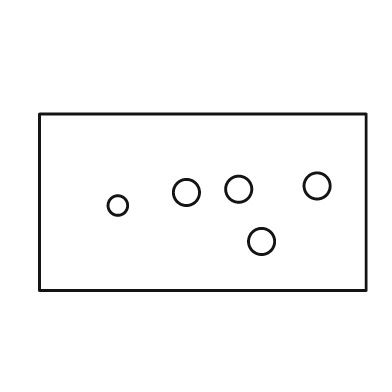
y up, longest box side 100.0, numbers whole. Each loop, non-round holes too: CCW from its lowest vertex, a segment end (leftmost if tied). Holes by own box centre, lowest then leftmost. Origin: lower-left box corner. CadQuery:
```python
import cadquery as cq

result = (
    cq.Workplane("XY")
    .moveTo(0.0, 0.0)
    .lineTo(100.0, 0.0)
    .lineTo(100.0, 54.0)
    .lineTo(0.0, 54.0)
    .close()
    .moveTo(68.0, 15.0)
    .circle(4.0)
    .moveTo(24.0, 26.0)
    .circle(3.0)
    .moveTo(45.0, 30.0)
    .circle(4.0)
    .moveTo(61.0, 31.0)
    .circle(4.0)
    .moveTo(85.0, 32.0)
    .circle(4.0)
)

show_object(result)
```